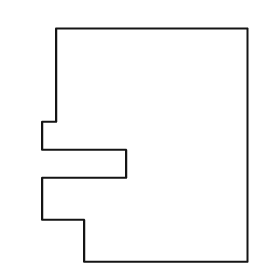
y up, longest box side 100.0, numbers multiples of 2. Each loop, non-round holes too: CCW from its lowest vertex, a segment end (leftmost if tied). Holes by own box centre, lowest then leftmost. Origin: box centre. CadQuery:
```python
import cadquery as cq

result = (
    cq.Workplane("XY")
    .moveTo(-26.0, -50.0)
    .lineTo(44.0, -50.0)
    .lineTo(44.0, 50.0)
    .lineTo(-38.0, 50.0)
    .lineTo(-38.0, 10.0)
    .lineTo(-44.0, 10.0)
    .lineTo(-44.0, -2.0)
    .lineTo(-8.0, -2.0)
    .lineTo(-8.0, -14.0)
    .lineTo(-44.0, -14.0)
    .lineTo(-44.0, -32.0)
    .lineTo(-26.0, -32.0)
    .close()
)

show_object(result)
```